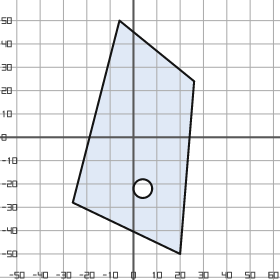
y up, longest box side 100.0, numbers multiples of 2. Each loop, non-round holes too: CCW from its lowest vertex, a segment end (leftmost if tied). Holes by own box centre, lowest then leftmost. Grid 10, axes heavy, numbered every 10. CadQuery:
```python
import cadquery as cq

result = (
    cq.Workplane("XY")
    .moveTo(20.0, -50.0)
    .lineTo(26.0, 24.0)
    .lineTo(-6.0, 50.0)
    .lineTo(-26.0, -28.0)
    .close()
    .moveTo(4.0, -22.0)
    .circle(4.0)
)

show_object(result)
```